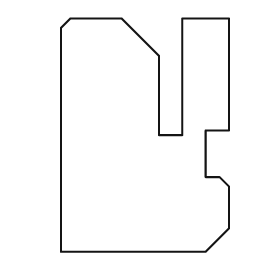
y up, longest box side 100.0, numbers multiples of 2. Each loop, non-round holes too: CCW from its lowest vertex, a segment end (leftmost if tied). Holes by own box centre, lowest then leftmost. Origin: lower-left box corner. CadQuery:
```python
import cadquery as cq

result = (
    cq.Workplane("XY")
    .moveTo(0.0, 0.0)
    .lineTo(62.0, 0.0)
    .lineTo(72.0, 10.0)
    .lineTo(72.0, 28.0)
    .lineTo(68.0, 32.0)
    .lineTo(62.0, 32.0)
    .lineTo(62.0, 52.0)
    .lineTo(72.0, 52.0)
    .lineTo(72.0, 100.0)
    .lineTo(52.0, 100.0)
    .lineTo(52.0, 50.0)
    .lineTo(42.0, 50.0)
    .lineTo(42.0, 84.0)
    .lineTo(26.0, 100.0)
    .lineTo(4.0, 100.0)
    .lineTo(0.0, 96.0)
    .close()
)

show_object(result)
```